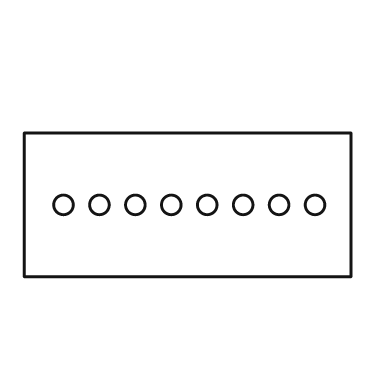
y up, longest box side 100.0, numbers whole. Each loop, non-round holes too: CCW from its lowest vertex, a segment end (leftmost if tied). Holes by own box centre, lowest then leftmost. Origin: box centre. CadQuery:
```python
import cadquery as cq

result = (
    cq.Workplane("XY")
    .moveTo(-50.0, -22.0)
    .lineTo(50.0, -22.0)
    .lineTo(50.0, 22.0)
    .lineTo(-50.0, 22.0)
    .close()
    .moveTo(-38.0, 0.0)
    .circle(3.0)
    .moveTo(-27.0, 0.0)
    .circle(3.0)
    .moveTo(-16.0, 0.0)
    .circle(3.0)
    .moveTo(-5.0, 0.0)
    .circle(3.0)
    .moveTo(6.0, 0.0)
    .circle(3.0)
    .moveTo(17.0, 0.0)
    .circle(3.0)
    .moveTo(28.0, 0.0)
    .circle(3.0)
    .moveTo(39.0, 0.0)
    .circle(3.0)
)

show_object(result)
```